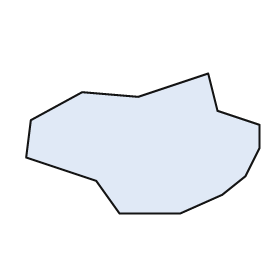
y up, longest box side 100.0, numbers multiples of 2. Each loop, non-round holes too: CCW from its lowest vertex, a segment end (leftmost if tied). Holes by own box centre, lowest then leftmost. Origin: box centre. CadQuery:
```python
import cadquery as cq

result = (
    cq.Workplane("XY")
    .moveTo(-10.0, -30.0)
    .lineTo(16.0, -30.0)
    .lineTo(34.0, -22.0)
    .lineTo(44.0, -14.0)
    .lineTo(50.0, -2.0)
    .lineTo(50.0, 8.0)
    .lineTo(32.0, 14.0)
    .lineTo(28.0, 30.0)
    .lineTo(-2.0, 20.0)
    .lineTo(-26.0, 22.0)
    .lineTo(-48.0, 10.0)
    .lineTo(-50.0, -6.0)
    .lineTo(-20.0, -16.0)
    .close()
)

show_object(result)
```